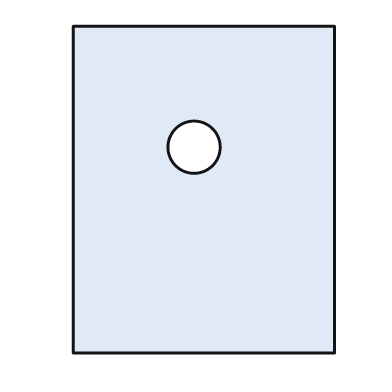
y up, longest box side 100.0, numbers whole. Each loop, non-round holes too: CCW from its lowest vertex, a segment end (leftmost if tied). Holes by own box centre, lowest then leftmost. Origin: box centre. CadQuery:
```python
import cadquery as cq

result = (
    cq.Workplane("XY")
    .moveTo(-40.0, -50.0)
    .lineTo(40.0, -50.0)
    .lineTo(40.0, 50.0)
    .lineTo(-40.0, 50.0)
    .close()
    .moveTo(-3.0, 13.0)
    .circle(8.0)
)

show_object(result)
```